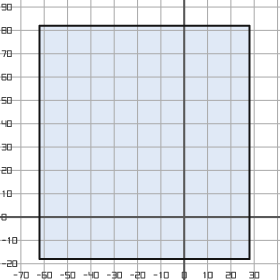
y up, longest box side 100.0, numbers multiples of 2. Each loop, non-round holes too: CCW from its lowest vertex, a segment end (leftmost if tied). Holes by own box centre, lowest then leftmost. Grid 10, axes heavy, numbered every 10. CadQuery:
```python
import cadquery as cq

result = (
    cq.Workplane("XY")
    .moveTo(-62.0, -18.0)
    .lineTo(28.0, -18.0)
    .lineTo(28.0, 82.0)
    .lineTo(-62.0, 82.0)
    .close()
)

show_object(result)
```